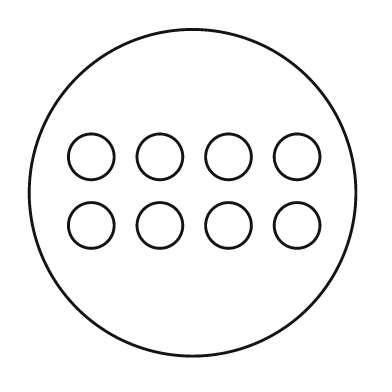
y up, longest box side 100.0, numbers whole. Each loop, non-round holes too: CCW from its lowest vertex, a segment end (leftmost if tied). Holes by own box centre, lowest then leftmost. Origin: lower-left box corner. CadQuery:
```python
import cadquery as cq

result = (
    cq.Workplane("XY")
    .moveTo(50.0, 50.0)
    .circle(50.0)
    .moveTo(19.0, 40.0)
    .circle(7.0)
    .moveTo(40.0, 40.0)
    .circle(7.0)
    .moveTo(61.0, 40.0)
    .circle(7.0)
    .moveTo(82.0, 40.0)
    .circle(7.0)
    .moveTo(19.0, 61.0)
    .circle(7.0)
    .moveTo(40.0, 61.0)
    .circle(7.0)
    .moveTo(61.0, 61.0)
    .circle(7.0)
    .moveTo(82.0, 61.0)
    .circle(7.0)
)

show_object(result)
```